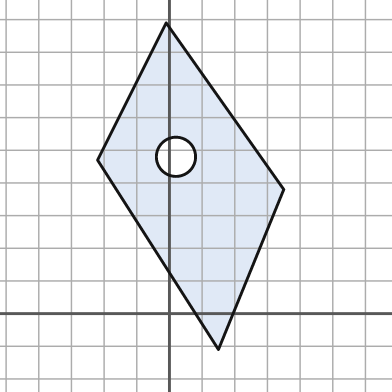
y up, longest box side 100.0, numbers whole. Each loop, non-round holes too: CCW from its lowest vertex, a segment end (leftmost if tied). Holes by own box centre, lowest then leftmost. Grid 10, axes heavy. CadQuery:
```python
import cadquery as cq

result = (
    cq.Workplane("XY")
    .moveTo(15.0, -11.0)
    .lineTo(35.0, 38.0)
    .lineTo(-1.0, 89.0)
    .lineTo(-22.0, 47.0)
    .close()
    .moveTo(2.0, 48.0)
    .circle(6.0)
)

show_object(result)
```